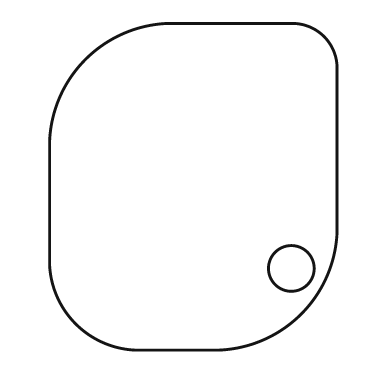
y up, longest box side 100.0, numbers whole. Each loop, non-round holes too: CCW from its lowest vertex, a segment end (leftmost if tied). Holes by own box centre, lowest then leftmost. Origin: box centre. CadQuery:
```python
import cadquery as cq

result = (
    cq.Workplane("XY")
    .moveTo(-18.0, -50.0)
    .lineTo(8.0, -50.0)
    .threePointArc((33.0, -39.0), (44.0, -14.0))
    .lineTo(44.0, 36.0)
    .threePointArc((40.0, 46.0), (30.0, 50.0))
    .lineTo(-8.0, 50.0)
    .threePointArc((-33.0, 39.0), (-44.0, 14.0))
    .lineTo(-44.0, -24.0)
    .threePointArc((-36.0, -42.0), (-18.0, -50.0))
    .close()
    .moveTo(30.0, -25.0)
    .circle(7.0)
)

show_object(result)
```